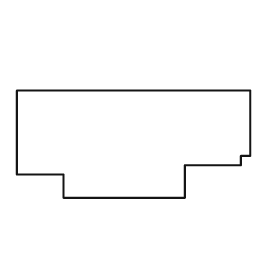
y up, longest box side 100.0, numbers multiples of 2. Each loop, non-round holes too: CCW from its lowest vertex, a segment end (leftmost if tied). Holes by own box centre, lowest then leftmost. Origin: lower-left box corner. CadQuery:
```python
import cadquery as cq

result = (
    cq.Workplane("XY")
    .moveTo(20.0, 0.0)
    .lineTo(72.0, 0.0)
    .lineTo(72.0, 14.0)
    .lineTo(96.0, 14.0)
    .lineTo(96.0, 18.0)
    .lineTo(100.0, 18.0)
    .lineTo(100.0, 46.0)
    .lineTo(0.0, 46.0)
    .lineTo(0.0, 10.0)
    .lineTo(20.0, 10.0)
    .close()
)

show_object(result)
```